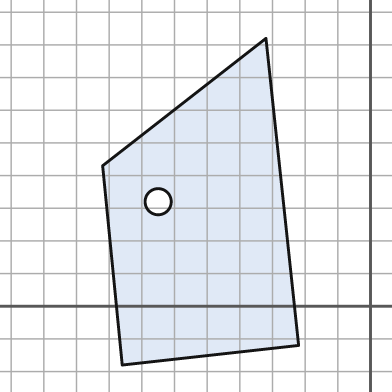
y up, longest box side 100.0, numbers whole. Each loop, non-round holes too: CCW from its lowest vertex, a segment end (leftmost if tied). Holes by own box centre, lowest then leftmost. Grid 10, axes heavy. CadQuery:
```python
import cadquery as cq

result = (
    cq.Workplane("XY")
    .moveTo(-76.0, -18.0)
    .lineTo(-22.0, -12.0)
    .lineTo(-32.0, 82.0)
    .lineTo(-82.0, 43.0)
    .close()
    .moveTo(-65.0, 32.0)
    .circle(4.0)
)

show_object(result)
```